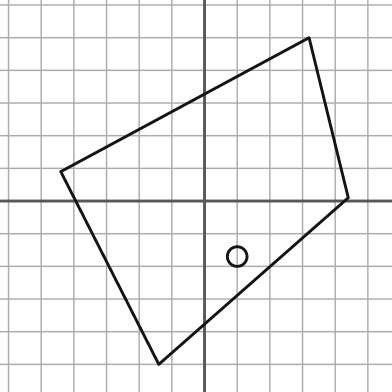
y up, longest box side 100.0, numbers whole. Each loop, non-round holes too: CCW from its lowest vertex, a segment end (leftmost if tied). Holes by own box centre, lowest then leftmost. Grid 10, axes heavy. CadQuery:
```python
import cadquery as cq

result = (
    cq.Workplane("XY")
    .moveTo(-14.0, -50.0)
    .lineTo(44.0, 1.0)
    .lineTo(32.0, 50.0)
    .lineTo(-44.0, 9.0)
    .close()
    .moveTo(10.0, -17.0)
    .circle(3.0)
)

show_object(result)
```